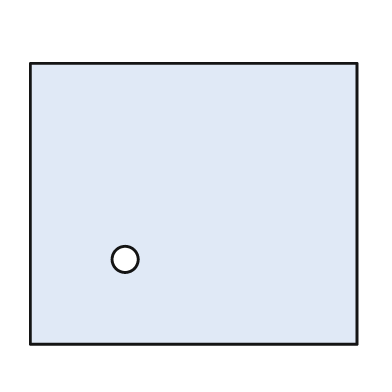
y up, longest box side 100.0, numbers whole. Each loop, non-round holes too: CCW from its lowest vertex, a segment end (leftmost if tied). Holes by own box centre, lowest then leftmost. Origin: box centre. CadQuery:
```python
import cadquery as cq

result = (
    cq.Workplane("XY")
    .moveTo(-50.0, -43.0)
    .lineTo(50.0, -43.0)
    .lineTo(50.0, 43.0)
    .lineTo(-50.0, 43.0)
    .close()
    .moveTo(-21.0, -17.0)
    .circle(4.0)
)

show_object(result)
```